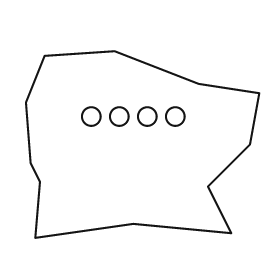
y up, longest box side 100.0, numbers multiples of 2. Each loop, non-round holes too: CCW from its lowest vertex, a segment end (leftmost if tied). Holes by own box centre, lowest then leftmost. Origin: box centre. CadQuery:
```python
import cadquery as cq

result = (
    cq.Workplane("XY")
    .moveTo(-46.0, -40.0)
    .lineTo(-4.0, -34.0)
    .lineTo(38.0, -38.0)
    .lineTo(28.0, -18.0)
    .lineTo(46.0, 0.0)
    .lineTo(50.0, 22.0)
    .lineTo(24.0, 26.0)
    .lineTo(-12.0, 40.0)
    .lineTo(-42.0, 38.0)
    .lineTo(-50.0, 18.0)
    .lineTo(-48.0, -8.0)
    .lineTo(-44.0, -16.0)
    .close()
    .moveTo(-22.0, 12.0)
    .circle(4.0)
    .moveTo(-10.0, 12.0)
    .circle(4.0)
    .moveTo(2.0, 12.0)
    .circle(4.0)
    .moveTo(14.0, 12.0)
    .circle(4.0)
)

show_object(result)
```